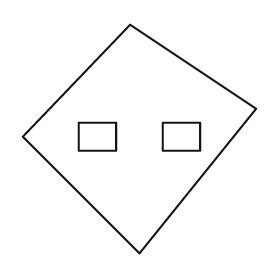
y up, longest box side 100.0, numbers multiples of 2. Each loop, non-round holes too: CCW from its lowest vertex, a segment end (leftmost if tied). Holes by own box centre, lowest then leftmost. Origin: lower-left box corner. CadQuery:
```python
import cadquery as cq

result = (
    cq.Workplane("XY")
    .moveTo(50.0, 0.0)
    .lineTo(100.0, 62.0)
    .lineTo(46.0, 98.0)
    .lineTo(0.0, 50.0)
    .close()
    .moveTo(24.0, 44.0)
    .lineTo(40.0, 44.0)
    .lineTo(40.0, 56.0)
    .lineTo(24.0, 56.0)
    .close()
    .moveTo(60.0, 44.0)
    .lineTo(76.0, 44.0)
    .lineTo(76.0, 56.0)
    .lineTo(60.0, 56.0)
    .close()
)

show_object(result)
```